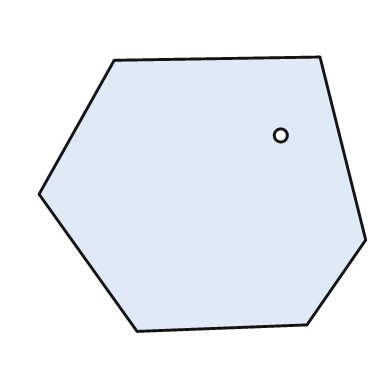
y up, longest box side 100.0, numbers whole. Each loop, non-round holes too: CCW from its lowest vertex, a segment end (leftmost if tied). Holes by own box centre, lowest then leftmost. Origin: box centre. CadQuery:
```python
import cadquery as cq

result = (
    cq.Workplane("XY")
    .moveTo(-20.0, -42.0)
    .lineTo(32.0, -40.0)
    .lineTo(50.0, -14.0)
    .lineTo(36.0, 42.0)
    .lineTo(-27.0, 41.0)
    .lineTo(-50.0, 0.0)
    .close()
    .moveTo(24.0, 18.0)
    .circle(2.0)
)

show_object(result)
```